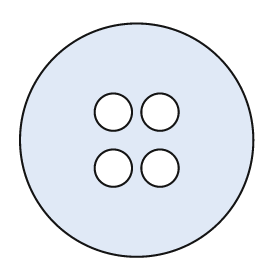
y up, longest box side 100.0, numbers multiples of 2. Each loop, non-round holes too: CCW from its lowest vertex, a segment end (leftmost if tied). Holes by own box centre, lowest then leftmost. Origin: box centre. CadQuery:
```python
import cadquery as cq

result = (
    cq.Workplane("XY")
    .moveTo(0.0, 0.0)
    .circle(50.0)
    .moveTo(-10.0, -12.0)
    .circle(8.0)
    .moveTo(10.0, -12.0)
    .circle(8.0)
    .moveTo(-10.0, 12.0)
    .circle(8.0)
    .moveTo(10.0, 12.0)
    .circle(8.0)
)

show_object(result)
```